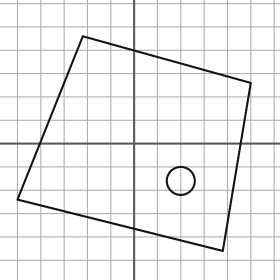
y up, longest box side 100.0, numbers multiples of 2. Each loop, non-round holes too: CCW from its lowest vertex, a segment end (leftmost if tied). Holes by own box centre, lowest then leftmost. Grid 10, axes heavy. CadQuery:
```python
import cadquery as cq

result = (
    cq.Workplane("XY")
    .moveTo(38.0, -46.0)
    .lineTo(50.0, 26.0)
    .lineTo(-22.0, 46.0)
    .lineTo(-50.0, -24.0)
    .close()
    .moveTo(20.0, -16.0)
    .circle(6.0)
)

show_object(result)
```